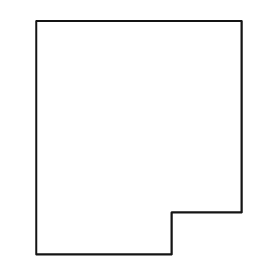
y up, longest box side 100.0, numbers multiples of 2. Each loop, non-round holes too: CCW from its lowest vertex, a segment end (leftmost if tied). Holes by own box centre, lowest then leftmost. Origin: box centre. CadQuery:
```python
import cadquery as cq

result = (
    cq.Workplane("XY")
    .moveTo(-44.0, -50.0)
    .lineTo(14.0, -50.0)
    .lineTo(14.0, -32.0)
    .lineTo(44.0, -32.0)
    .lineTo(44.0, 50.0)
    .lineTo(-44.0, 50.0)
    .close()
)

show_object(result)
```